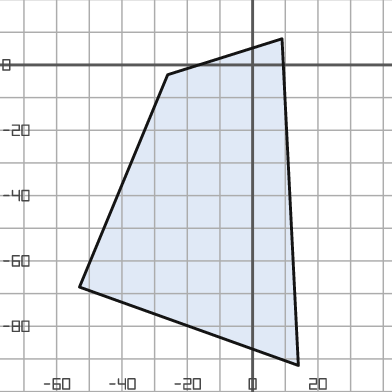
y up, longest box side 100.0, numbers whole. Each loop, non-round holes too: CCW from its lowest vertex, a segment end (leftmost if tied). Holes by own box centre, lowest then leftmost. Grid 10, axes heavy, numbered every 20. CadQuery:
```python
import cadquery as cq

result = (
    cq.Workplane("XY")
    .moveTo(14.0, -92.0)
    .lineTo(9.0, 8.0)
    .lineTo(-26.0, -3.0)
    .lineTo(-53.0, -68.0)
    .close()
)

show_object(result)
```